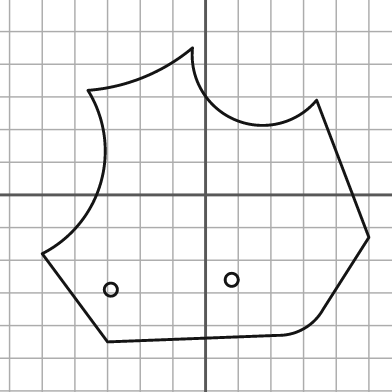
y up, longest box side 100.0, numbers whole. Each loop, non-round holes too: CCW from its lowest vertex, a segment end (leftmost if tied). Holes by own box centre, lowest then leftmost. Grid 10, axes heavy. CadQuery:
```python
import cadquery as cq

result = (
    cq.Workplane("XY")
    .moveTo(-30.0, -45.0)
    .lineTo(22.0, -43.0)
    .threePointArc((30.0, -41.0), (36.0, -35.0))
    .lineTo(50.0, -13.0)
    .lineTo(34.0, 29.0)
    .threePointArc((9.0, 23.0), (-4.0, 45.0))
    .threePointArc((-19.0, 36.0), (-36.0, 32.0))
    .threePointArc((-32.0, 4.0), (-50.0, -18.0))
    .close()
    .moveTo(-29.0, -29.0)
    .circle(2.0)
    .moveTo(8.0, -26.0)
    .circle(2.0)
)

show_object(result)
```